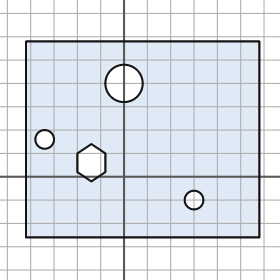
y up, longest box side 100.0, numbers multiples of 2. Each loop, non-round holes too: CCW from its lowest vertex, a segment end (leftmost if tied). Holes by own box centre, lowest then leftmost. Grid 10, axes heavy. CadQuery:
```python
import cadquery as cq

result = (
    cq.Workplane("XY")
    .moveTo(-42.0, -26.0)
    .lineTo(58.0, -26.0)
    .lineTo(58.0, 58.0)
    .lineTo(-42.0, 58.0)
    .close()
    .moveTo(30.0, -10.0)
    .circle(4.0)
    .moveTo(-14.0, -2.0)
    .lineTo(-8.0, 2.0)
    .lineTo(-8.0, 10.0)
    .lineTo(-14.0, 14.0)
    .lineTo(-20.0, 10.0)
    .lineTo(-20.0, 2.0)
    .close()
    .moveTo(-34.0, 16.0)
    .circle(4.0)
    .moveTo(0.0, 40.0)
    .circle(8.0)
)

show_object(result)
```